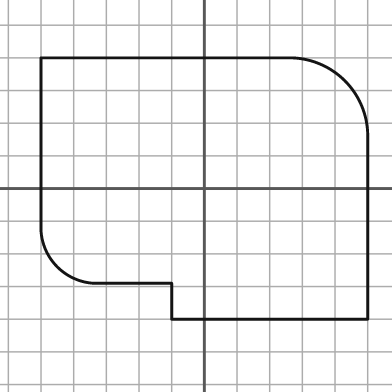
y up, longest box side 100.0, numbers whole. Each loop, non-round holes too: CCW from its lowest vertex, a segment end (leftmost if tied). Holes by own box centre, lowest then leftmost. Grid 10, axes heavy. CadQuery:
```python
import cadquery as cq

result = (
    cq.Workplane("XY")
    .moveTo(-10.0, -40.0)
    .lineTo(50.0, -40.0)
    .lineTo(50.0, 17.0)
    .threePointArc((43.0, 33.0), (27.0, 40.0))
    .lineTo(-50.0, 40.0)
    .lineTo(-50.0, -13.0)
    .threePointArc((-45.0, -24.0), (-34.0, -29.0))
    .lineTo(-10.0, -29.0)
    .close()
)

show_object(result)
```